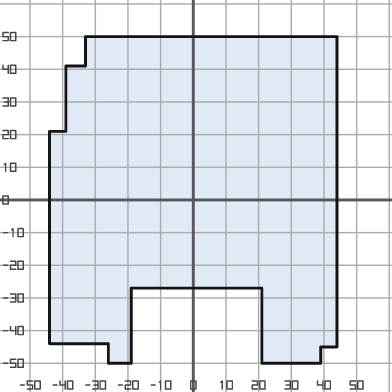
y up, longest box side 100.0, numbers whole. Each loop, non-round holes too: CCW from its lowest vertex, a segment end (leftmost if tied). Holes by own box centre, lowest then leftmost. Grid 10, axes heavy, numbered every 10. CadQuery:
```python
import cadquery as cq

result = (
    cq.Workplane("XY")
    .moveTo(-26.0, -50.0)
    .lineTo(-19.0, -50.0)
    .lineTo(-19.0, -27.0)
    .lineTo(21.0, -27.0)
    .lineTo(21.0, -50.0)
    .lineTo(39.0, -50.0)
    .lineTo(39.0, -45.0)
    .lineTo(44.0, -45.0)
    .lineTo(44.0, 50.0)
    .lineTo(-33.0, 50.0)
    .lineTo(-33.0, 41.0)
    .lineTo(-39.0, 41.0)
    .lineTo(-39.0, 21.0)
    .lineTo(-44.0, 21.0)
    .lineTo(-44.0, -44.0)
    .lineTo(-26.0, -44.0)
    .close()
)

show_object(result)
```